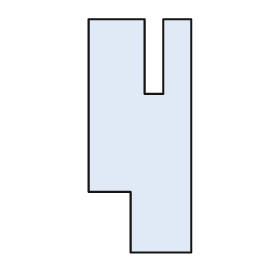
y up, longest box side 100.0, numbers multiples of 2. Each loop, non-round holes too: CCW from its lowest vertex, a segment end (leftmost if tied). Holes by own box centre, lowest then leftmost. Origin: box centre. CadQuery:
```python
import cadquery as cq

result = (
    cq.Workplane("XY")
    .moveTo(-4.0, -50.0)
    .lineTo(22.0, -50.0)
    .lineTo(22.0, 50.0)
    .lineTo(10.0, 50.0)
    .lineTo(10.0, 18.0)
    .lineTo(2.0, 18.0)
    .lineTo(2.0, 50.0)
    .lineTo(-22.0, 50.0)
    .lineTo(-22.0, -24.0)
    .lineTo(-4.0, -24.0)
    .close()
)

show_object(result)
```